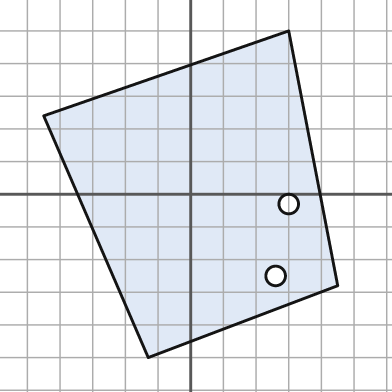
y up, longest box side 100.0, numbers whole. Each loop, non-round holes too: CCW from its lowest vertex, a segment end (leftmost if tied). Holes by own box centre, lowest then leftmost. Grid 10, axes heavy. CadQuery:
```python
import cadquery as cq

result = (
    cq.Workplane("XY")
    .moveTo(-13.0, -50.0)
    .lineTo(45.0, -28.0)
    .lineTo(30.0, 50.0)
    .lineTo(-45.0, 24.0)
    .close()
    .moveTo(26.0, -25.0)
    .circle(3.0)
    .moveTo(30.0, -3.0)
    .circle(3.0)
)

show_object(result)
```